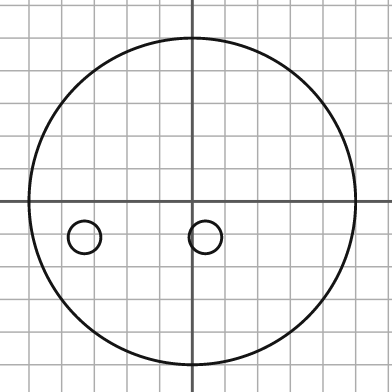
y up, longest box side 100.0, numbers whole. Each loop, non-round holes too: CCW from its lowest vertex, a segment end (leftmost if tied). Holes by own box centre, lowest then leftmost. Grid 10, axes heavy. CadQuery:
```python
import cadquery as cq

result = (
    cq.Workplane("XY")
    .moveTo(0.0, 0.0)
    .circle(50.0)
    .moveTo(-33.0, -11.0)
    .circle(5.0)
    .moveTo(4.0, -11.0)
    .circle(5.0)
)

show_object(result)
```